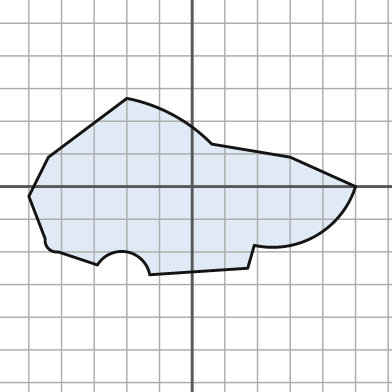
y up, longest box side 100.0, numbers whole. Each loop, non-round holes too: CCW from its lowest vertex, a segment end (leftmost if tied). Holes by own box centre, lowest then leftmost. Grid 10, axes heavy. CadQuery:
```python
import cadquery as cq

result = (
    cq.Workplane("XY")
    .moveTo(-13.0, -27.0)
    .lineTo(17.0, -25.0)
    .lineTo(19.0, -18.0)
    .threePointArc((38.0, -15.0), (50.0, 0.0))
    .lineTo(30.0, 9.0)
    .lineTo(6.0, 13.0)
    .threePointArc((-6.0, 22.0), (-20.0, 27.0))
    .lineTo(-44.0, 9.0)
    .lineTo(-50.0, -3.0)
    .lineTo(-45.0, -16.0)
    .threePointArc((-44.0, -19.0), (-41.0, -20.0))
    .lineTo(-29.0, -24.0)
    .threePointArc((-20.0, -20.0), (-13.0, -27.0))
    .close()
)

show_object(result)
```